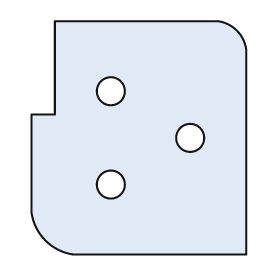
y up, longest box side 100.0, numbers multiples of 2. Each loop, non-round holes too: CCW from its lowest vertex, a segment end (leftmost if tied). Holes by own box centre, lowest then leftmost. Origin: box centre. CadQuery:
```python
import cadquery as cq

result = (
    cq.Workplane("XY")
    .moveTo(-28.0, -50.0)
    .lineTo(46.0, -50.0)
    .lineTo(46.0, 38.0)
    .threePointArc((42.0, 46.0), (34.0, 50.0))
    .lineTo(-36.0, 50.0)
    .lineTo(-36.0, 10.0)
    .lineTo(-46.0, 10.0)
    .lineTo(-46.0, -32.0)
    .threePointArc((-40.0, -44.0), (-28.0, -50.0))
    .close()
    .moveTo(-12.0, -20.0)
    .circle(6.0)
    .moveTo(22.0, 0.0)
    .circle(6.0)
    .moveTo(-12.0, 20.0)
    .circle(6.0)
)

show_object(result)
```